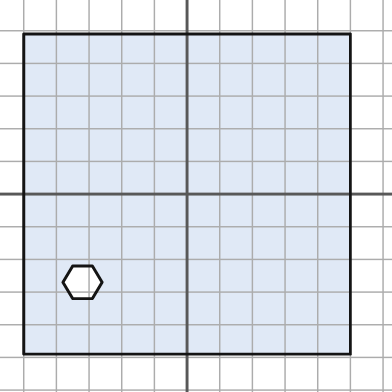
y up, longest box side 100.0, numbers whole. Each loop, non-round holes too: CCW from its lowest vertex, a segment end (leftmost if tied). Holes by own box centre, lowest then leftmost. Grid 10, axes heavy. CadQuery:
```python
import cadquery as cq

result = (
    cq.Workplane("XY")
    .moveTo(-50.0, -49.0)
    .lineTo(50.0, -49.0)
    .lineTo(50.0, 49.0)
    .lineTo(-50.0, 49.0)
    .close()
    .moveTo(-35.0, -32.0)
    .lineTo(-29.0, -32.0)
    .lineTo(-26.0, -27.0)
    .lineTo(-29.0, -22.0)
    .lineTo(-35.0, -22.0)
    .lineTo(-38.0, -27.0)
    .close()
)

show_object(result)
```